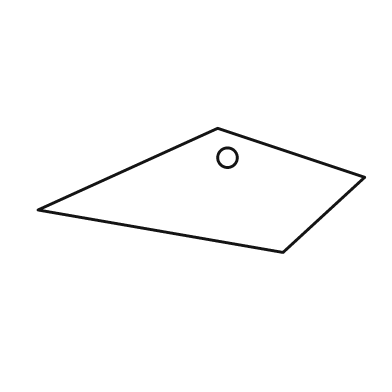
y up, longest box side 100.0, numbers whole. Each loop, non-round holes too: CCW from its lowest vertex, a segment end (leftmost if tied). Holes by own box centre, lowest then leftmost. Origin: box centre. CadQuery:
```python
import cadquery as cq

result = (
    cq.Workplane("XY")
    .moveTo(25.0, -19.0)
    .lineTo(50.0, 4.0)
    .lineTo(5.0, 19.0)
    .lineTo(-50.0, -6.0)
    .close()
    .moveTo(8.0, 10.0)
    .circle(3.0)
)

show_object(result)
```